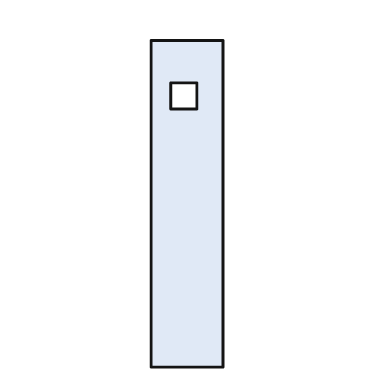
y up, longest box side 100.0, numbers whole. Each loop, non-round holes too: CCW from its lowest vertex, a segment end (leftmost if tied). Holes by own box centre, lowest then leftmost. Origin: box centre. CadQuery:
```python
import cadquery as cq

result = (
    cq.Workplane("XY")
    .moveTo(-11.0, -50.0)
    .lineTo(11.0, -50.0)
    .lineTo(11.0, 50.0)
    .lineTo(-11.0, 50.0)
    .close()
    .moveTo(-5.0, 29.0)
    .lineTo(3.0, 29.0)
    .lineTo(3.0, 37.0)
    .lineTo(-5.0, 37.0)
    .close()
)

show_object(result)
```